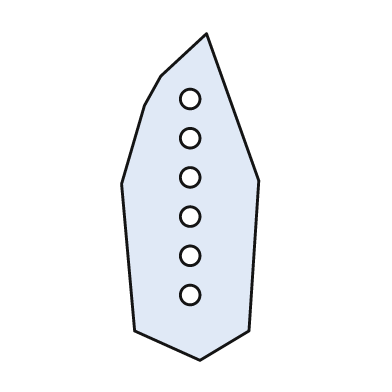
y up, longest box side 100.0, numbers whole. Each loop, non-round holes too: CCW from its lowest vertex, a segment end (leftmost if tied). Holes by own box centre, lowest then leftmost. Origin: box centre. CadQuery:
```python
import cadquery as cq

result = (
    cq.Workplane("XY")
    .moveTo(3.0, -50.0)
    .lineTo(18.0, -41.0)
    .lineTo(21.0, 5.0)
    .lineTo(5.0, 50.0)
    .lineTo(-9.0, 37.0)
    .lineTo(-14.0, 28.0)
    .lineTo(-21.0, 4.0)
    .lineTo(-17.0, -41.0)
    .close()
    .moveTo(0.0, -30.0)
    .circle(3.0)
    .moveTo(0.0, -18.0)
    .circle(3.0)
    .moveTo(0.0, -6.0)
    .circle(3.0)
    .moveTo(0.0, 6.0)
    .circle(3.0)
    .moveTo(0.0, 18.0)
    .circle(3.0)
    .moveTo(0.0, 30.0)
    .circle(3.0)
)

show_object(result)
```